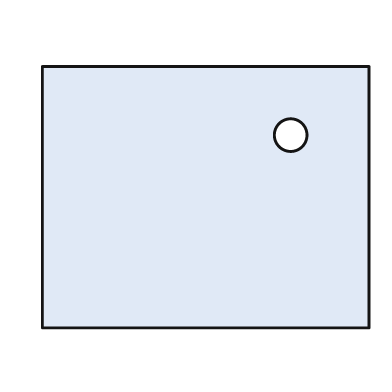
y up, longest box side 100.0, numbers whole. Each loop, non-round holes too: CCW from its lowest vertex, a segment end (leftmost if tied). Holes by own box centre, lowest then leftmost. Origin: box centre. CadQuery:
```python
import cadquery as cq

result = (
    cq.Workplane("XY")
    .moveTo(-50.0, -40.0)
    .lineTo(50.0, -40.0)
    .lineTo(50.0, 40.0)
    .lineTo(-50.0, 40.0)
    .close()
    .moveTo(26.0, 19.0)
    .circle(5.0)
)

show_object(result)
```